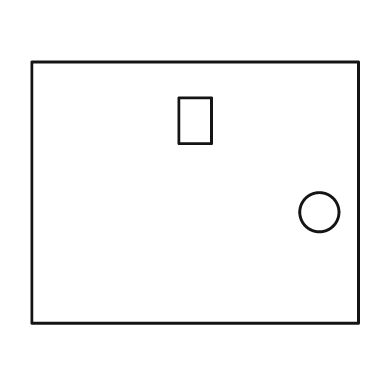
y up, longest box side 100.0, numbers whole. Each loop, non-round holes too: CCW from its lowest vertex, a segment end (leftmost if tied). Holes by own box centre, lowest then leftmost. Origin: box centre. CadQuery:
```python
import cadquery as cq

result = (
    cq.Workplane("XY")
    .moveTo(-50.0, -40.0)
    .lineTo(50.0, -40.0)
    .lineTo(50.0, 40.0)
    .lineTo(-50.0, 40.0)
    .close()
    .moveTo(38.0, -6.0)
    .circle(6.0)
    .moveTo(-5.0, 15.0)
    .lineTo(5.0, 15.0)
    .lineTo(5.0, 29.0)
    .lineTo(-5.0, 29.0)
    .close()
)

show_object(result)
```